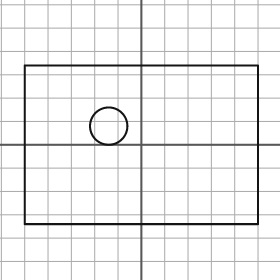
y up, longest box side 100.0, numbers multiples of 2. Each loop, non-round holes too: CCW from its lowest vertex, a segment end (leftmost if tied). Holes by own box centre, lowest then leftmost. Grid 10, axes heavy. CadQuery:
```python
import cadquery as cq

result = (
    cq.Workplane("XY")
    .moveTo(-50.0, -34.0)
    .lineTo(50.0, -34.0)
    .lineTo(50.0, 34.0)
    .lineTo(-50.0, 34.0)
    .close()
    .moveTo(-14.0, 8.0)
    .circle(8.0)
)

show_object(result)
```